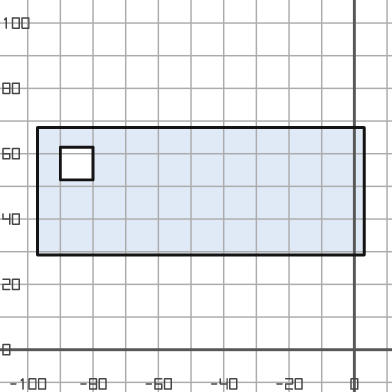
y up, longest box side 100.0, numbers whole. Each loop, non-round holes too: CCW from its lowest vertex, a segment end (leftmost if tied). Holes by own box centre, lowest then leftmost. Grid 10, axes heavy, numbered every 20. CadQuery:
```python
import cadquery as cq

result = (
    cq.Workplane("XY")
    .moveTo(-97.0, 29.0)
    .lineTo(3.0, 29.0)
    .lineTo(3.0, 68.0)
    .lineTo(-97.0, 68.0)
    .close()
    .moveTo(-90.0, 52.0)
    .lineTo(-80.0, 52.0)
    .lineTo(-80.0, 62.0)
    .lineTo(-90.0, 62.0)
    .close()
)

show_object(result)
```